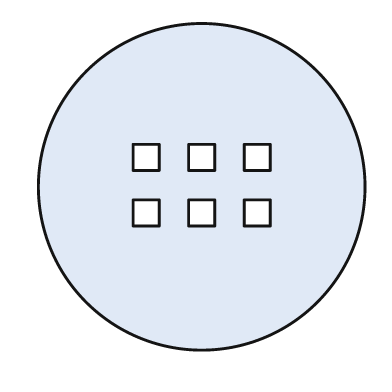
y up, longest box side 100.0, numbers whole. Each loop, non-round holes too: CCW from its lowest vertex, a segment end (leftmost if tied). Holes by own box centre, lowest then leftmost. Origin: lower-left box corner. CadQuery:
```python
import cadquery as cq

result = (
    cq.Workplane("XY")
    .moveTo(50.0, 50.0)
    .circle(50.0)
    .moveTo(29.0, 38.0)
    .lineTo(37.0, 38.0)
    .lineTo(37.0, 46.0)
    .lineTo(29.0, 46.0)
    .close()
    .moveTo(46.0, 38.0)
    .lineTo(54.0, 38.0)
    .lineTo(54.0, 46.0)
    .lineTo(46.0, 46.0)
    .close()
    .moveTo(63.0, 38.0)
    .lineTo(71.0, 38.0)
    .lineTo(71.0, 46.0)
    .lineTo(63.0, 46.0)
    .close()
    .moveTo(29.0, 55.0)
    .lineTo(37.0, 55.0)
    .lineTo(37.0, 63.0)
    .lineTo(29.0, 63.0)
    .close()
    .moveTo(46.0, 55.0)
    .lineTo(54.0, 55.0)
    .lineTo(54.0, 63.0)
    .lineTo(46.0, 63.0)
    .close()
    .moveTo(63.0, 55.0)
    .lineTo(71.0, 55.0)
    .lineTo(71.0, 63.0)
    .lineTo(63.0, 63.0)
    .close()
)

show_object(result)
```